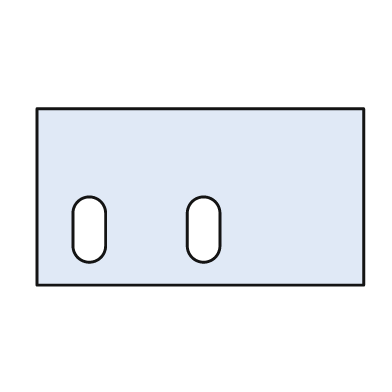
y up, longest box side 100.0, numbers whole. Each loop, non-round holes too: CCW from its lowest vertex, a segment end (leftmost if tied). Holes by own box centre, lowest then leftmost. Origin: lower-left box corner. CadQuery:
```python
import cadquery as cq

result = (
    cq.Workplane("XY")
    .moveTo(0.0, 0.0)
    .lineTo(100.0, 0.0)
    .lineTo(100.0, 54.0)
    .lineTo(0.0, 54.0)
    .close()
    .moveTo(11.0, 12.0)
    .threePointArc((16.0, 7.0), (21.0, 12.0))
    .lineTo(21.0, 22.0)
    .threePointArc((16.0, 27.0), (11.0, 22.0))
    .close()
    .moveTo(46.0, 12.0)
    .threePointArc((51.0, 7.0), (56.0, 12.0))
    .lineTo(56.0, 22.0)
    .threePointArc((51.0, 27.0), (46.0, 22.0))
    .close()
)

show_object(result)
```